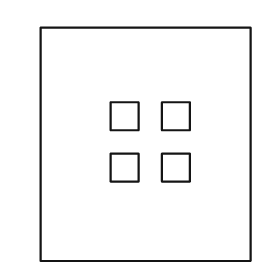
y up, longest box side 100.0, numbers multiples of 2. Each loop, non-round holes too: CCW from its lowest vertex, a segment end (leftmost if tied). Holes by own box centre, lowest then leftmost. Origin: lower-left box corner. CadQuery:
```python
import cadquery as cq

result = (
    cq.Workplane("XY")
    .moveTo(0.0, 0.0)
    .lineTo(90.0, 0.0)
    .lineTo(90.0, 100.0)
    .lineTo(0.0, 100.0)
    .close()
    .moveTo(30.0, 34.0)
    .lineTo(42.0, 34.0)
    .lineTo(42.0, 46.0)
    .lineTo(30.0, 46.0)
    .close()
    .moveTo(52.0, 34.0)
    .lineTo(64.0, 34.0)
    .lineTo(64.0, 46.0)
    .lineTo(52.0, 46.0)
    .close()
    .moveTo(30.0, 56.0)
    .lineTo(42.0, 56.0)
    .lineTo(42.0, 68.0)
    .lineTo(30.0, 68.0)
    .close()
    .moveTo(52.0, 56.0)
    .lineTo(64.0, 56.0)
    .lineTo(64.0, 68.0)
    .lineTo(52.0, 68.0)
    .close()
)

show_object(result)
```